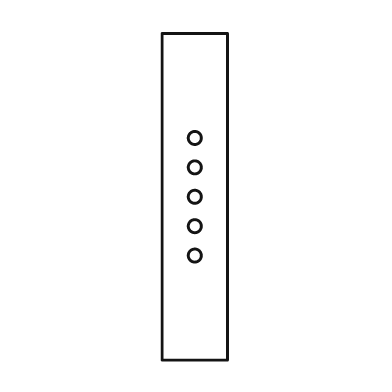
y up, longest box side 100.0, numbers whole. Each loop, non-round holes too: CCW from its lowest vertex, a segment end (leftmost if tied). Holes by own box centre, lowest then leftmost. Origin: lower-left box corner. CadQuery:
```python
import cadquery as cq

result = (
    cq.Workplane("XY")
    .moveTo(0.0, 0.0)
    .lineTo(20.0, 0.0)
    .lineTo(20.0, 100.0)
    .lineTo(0.0, 100.0)
    .close()
    .moveTo(10.0, 32.0)
    .circle(2.0)
    .moveTo(10.0, 41.0)
    .circle(2.0)
    .moveTo(10.0, 50.0)
    .circle(2.0)
    .moveTo(10.0, 59.0)
    .circle(2.0)
    .moveTo(10.0, 68.0)
    .circle(2.0)
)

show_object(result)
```